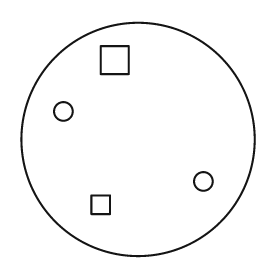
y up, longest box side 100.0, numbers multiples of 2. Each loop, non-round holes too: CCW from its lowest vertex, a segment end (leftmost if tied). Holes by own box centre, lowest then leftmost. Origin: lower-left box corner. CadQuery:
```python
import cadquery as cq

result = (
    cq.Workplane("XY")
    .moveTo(50.0, 50.0)
    .circle(50.0)
    .moveTo(30.0, 18.0)
    .lineTo(38.0, 18.0)
    .lineTo(38.0, 26.0)
    .lineTo(30.0, 26.0)
    .close()
    .moveTo(78.0, 32.0)
    .circle(4.0)
    .moveTo(18.0, 62.0)
    .circle(4.0)
    .moveTo(34.0, 78.0)
    .lineTo(46.0, 78.0)
    .lineTo(46.0, 90.0)
    .lineTo(34.0, 90.0)
    .close()
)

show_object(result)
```